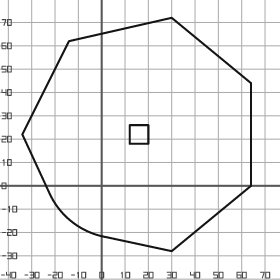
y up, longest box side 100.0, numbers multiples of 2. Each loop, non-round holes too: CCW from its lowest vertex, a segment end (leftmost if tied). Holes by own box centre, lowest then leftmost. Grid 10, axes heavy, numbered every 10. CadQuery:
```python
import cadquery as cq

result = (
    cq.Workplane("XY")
    .moveTo(30.0, -28.0)
    .lineTo(64.0, 0.0)
    .lineTo(64.0, 44.0)
    .lineTo(30.0, 72.0)
    .lineTo(-14.0, 62.0)
    .lineTo(-34.0, 22.0)
    .lineTo(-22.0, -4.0)
    .threePointArc((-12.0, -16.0), (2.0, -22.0))
    .close()
    .moveTo(12.0, 18.0)
    .lineTo(20.0, 18.0)
    .lineTo(20.0, 26.0)
    .lineTo(12.0, 26.0)
    .close()
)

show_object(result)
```